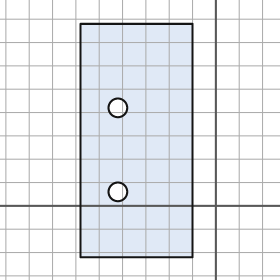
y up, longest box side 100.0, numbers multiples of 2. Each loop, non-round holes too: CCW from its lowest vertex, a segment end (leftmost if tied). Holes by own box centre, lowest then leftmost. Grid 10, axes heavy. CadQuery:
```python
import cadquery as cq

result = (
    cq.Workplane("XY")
    .moveTo(-58.0, -22.0)
    .lineTo(-10.0, -22.0)
    .lineTo(-10.0, 78.0)
    .lineTo(-58.0, 78.0)
    .close()
    .moveTo(-42.0, 6.0)
    .circle(4.0)
    .moveTo(-42.0, 42.0)
    .circle(4.0)
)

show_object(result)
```